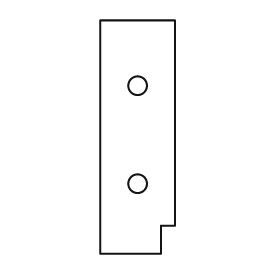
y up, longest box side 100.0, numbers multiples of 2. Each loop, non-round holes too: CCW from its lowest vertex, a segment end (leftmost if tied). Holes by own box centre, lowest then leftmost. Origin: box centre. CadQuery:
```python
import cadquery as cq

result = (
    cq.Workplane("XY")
    .moveTo(-16.0, -50.0)
    .lineTo(10.0, -50.0)
    .lineTo(10.0, -38.0)
    .lineTo(16.0, -38.0)
    .lineTo(16.0, 50.0)
    .lineTo(-16.0, 50.0)
    .close()
    .moveTo(0.0, -20.0)
    .circle(4.0)
    .moveTo(0.0, 22.0)
    .circle(4.0)
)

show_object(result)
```